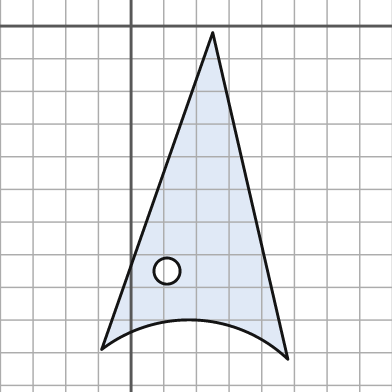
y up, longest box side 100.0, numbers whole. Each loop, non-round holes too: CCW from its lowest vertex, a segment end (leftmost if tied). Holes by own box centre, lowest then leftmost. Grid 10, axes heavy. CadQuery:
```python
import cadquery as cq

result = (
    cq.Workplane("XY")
    .moveTo(48.0, -102.0)
    .lineTo(25.0, -2.0)
    .lineTo(-9.0, -99.0)
    .threePointArc((20.0, -90.0), (48.0, -102.0))
    .close()
    .moveTo(11.0, -75.0)
    .circle(4.0)
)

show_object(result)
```